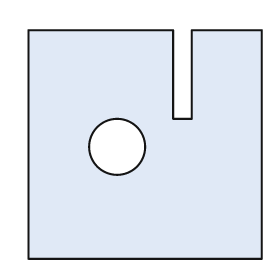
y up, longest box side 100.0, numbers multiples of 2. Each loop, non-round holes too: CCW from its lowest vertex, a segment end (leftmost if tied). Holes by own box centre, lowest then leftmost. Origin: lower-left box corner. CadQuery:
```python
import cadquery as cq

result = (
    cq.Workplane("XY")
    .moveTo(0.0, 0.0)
    .lineTo(100.0, 0.0)
    .lineTo(100.0, 98.0)
    .lineTo(70.0, 98.0)
    .lineTo(70.0, 60.0)
    .lineTo(62.0, 60.0)
    .lineTo(62.0, 98.0)
    .lineTo(0.0, 98.0)
    .close()
    .moveTo(38.0, 48.0)
    .circle(12.0)
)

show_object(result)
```